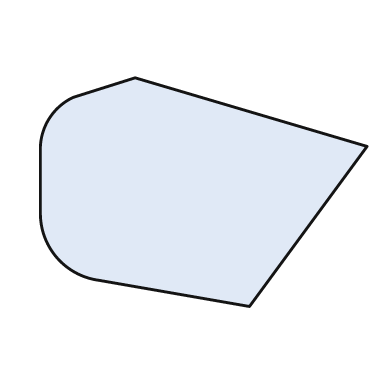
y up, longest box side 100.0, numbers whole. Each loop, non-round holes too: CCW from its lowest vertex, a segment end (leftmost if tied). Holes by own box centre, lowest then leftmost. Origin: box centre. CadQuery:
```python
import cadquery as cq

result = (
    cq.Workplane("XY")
    .moveTo(14.0, -35.0)
    .lineTo(50.0, 14.0)
    .lineTo(-21.0, 35.0)
    .lineTo(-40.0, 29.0)
    .threePointArc((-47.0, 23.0), (-50.0, 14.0))
    .lineTo(-50.0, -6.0)
    .threePointArc((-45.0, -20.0), (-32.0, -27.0))
    .close()
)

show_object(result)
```